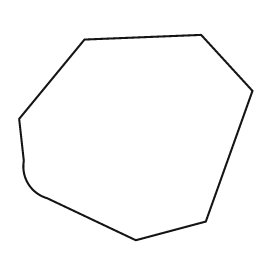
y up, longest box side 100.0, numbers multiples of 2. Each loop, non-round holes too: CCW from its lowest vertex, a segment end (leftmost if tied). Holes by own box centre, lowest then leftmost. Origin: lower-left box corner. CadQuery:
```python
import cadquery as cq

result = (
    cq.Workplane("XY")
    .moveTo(50.0, 0.0)
    .lineTo(80.0, 8.0)
    .lineTo(100.0, 64.0)
    .lineTo(78.0, 88.0)
    .lineTo(28.0, 86.0)
    .lineTo(0.0, 52.0)
    .lineTo(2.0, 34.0)
    .threePointArc((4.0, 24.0), (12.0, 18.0))
    .close()
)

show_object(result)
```